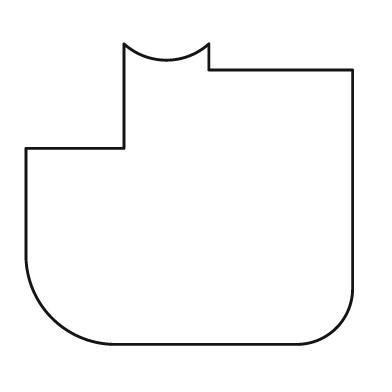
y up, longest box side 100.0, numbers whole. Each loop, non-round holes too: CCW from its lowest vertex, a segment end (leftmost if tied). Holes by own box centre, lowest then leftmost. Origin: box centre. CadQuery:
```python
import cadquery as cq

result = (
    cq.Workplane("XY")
    .moveTo(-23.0, -46.0)
    .lineTo(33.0, -46.0)
    .threePointArc((45.0, -41.0), (50.0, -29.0))
    .lineTo(50.0, 38.0)
    .lineTo(6.0, 38.0)
    .lineTo(6.0, 46.0)
    .threePointArc((-7.0, 41.0), (-20.0, 46.0))
    .lineTo(-20.0, 14.0)
    .lineTo(-50.0, 14.0)
    .lineTo(-50.0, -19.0)
    .threePointArc((-42.0, -38.0), (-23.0, -46.0))
    .close()
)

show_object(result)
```